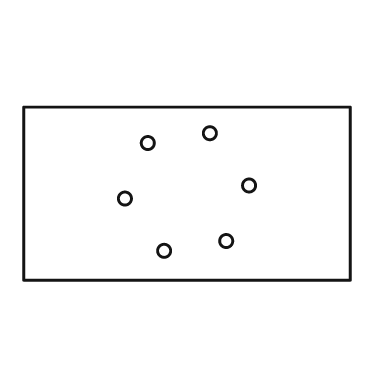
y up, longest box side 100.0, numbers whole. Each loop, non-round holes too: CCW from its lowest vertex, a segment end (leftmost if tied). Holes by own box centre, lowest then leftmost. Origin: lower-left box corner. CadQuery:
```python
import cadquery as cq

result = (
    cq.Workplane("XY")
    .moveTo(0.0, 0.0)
    .lineTo(100.0, 0.0)
    .lineTo(100.0, 53.0)
    .lineTo(0.0, 53.0)
    .close()
    .moveTo(43.0, 9.0)
    .circle(2.0)
    .moveTo(62.0, 12.0)
    .circle(2.0)
    .moveTo(31.0, 25.0)
    .circle(2.0)
    .moveTo(69.0, 29.0)
    .circle(2.0)
    .moveTo(38.0, 42.0)
    .circle(2.0)
    .moveTo(57.0, 45.0)
    .circle(2.0)
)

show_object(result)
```